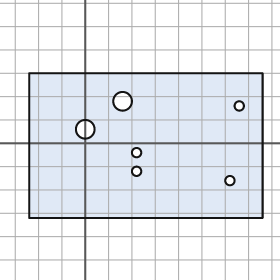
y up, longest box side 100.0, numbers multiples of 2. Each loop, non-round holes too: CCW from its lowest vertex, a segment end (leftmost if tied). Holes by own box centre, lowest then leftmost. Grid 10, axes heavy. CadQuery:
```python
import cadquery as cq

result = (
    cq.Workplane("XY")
    .moveTo(-24.0, -32.0)
    .lineTo(76.0, -32.0)
    .lineTo(76.0, 30.0)
    .lineTo(-24.0, 30.0)
    .close()
    .moveTo(62.0, -16.0)
    .circle(2.0)
    .moveTo(22.0, -12.0)
    .circle(2.0)
    .moveTo(22.0, -4.0)
    .circle(2.0)
    .moveTo(0.0, 6.0)
    .circle(4.0)
    .moveTo(66.0, 16.0)
    .circle(2.0)
    .moveTo(16.0, 18.0)
    .circle(4.0)
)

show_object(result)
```